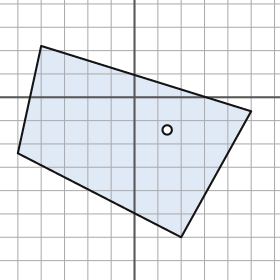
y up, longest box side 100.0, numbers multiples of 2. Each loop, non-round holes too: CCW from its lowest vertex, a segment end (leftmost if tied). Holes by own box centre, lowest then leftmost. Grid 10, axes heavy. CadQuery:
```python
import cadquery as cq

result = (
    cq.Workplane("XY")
    .moveTo(20.0, -60.0)
    .lineTo(50.0, -6.0)
    .lineTo(-40.0, 22.0)
    .lineTo(-50.0, -24.0)
    .close()
    .moveTo(14.0, -14.0)
    .circle(2.0)
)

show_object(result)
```